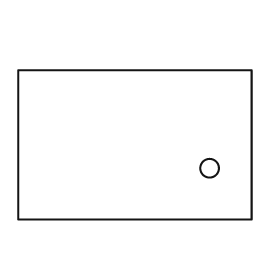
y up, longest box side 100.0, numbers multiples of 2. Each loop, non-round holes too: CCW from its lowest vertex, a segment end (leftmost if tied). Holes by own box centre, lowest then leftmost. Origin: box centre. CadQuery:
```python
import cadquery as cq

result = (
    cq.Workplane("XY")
    .moveTo(-50.0, -32.0)
    .lineTo(50.0, -32.0)
    .lineTo(50.0, 32.0)
    .lineTo(-50.0, 32.0)
    .close()
    .moveTo(32.0, -10.0)
    .circle(4.0)
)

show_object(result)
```